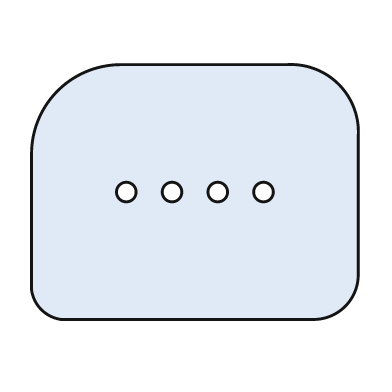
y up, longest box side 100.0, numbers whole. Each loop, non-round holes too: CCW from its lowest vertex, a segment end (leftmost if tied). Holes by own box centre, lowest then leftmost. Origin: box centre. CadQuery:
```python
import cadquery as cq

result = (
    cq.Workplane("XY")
    .moveTo(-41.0, -39.0)
    .lineTo(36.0, -39.0)
    .threePointArc((46.0, -35.0), (50.0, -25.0))
    .lineTo(50.0, 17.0)
    .threePointArc((44.0, 33.0), (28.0, 39.0))
    .lineTo(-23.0, 39.0)
    .threePointArc((-42.0, 31.0), (-50.0, 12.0))
    .lineTo(-50.0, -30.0)
    .threePointArc((-47.0, -36.0), (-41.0, -39.0))
    .close()
    .moveTo(-21.0, 0.0)
    .circle(3.0)
    .moveTo(-7.0, 0.0)
    .circle(3.0)
    .moveTo(7.0, 0.0)
    .circle(3.0)
    .moveTo(21.0, 0.0)
    .circle(3.0)
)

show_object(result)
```